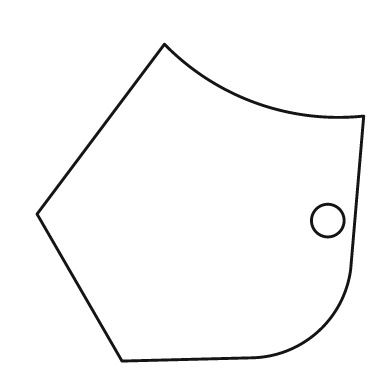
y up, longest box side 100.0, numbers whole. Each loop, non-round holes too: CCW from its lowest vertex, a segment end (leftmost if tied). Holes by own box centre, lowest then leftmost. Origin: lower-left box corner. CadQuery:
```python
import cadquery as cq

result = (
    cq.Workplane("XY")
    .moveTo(26.0, 0.0)
    .lineTo(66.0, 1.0)
    .threePointArc((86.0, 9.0), (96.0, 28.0))
    .lineTo(100.0, 75.0)
    .threePointArc((67.0, 79.0), (39.0, 97.0))
    .lineTo(0.0, 45.0)
    .close()
    .moveTo(89.0, 43.0)
    .circle(5.0)
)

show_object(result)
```